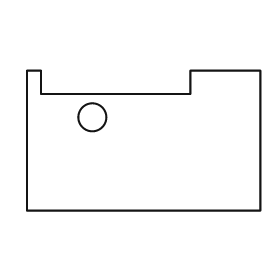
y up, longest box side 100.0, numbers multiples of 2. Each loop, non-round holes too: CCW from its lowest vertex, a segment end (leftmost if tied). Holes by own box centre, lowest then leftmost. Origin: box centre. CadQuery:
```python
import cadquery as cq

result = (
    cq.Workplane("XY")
    .moveTo(-50.0, -30.0)
    .lineTo(50.0, -30.0)
    .lineTo(50.0, 30.0)
    .lineTo(20.0, 30.0)
    .lineTo(20.0, 20.0)
    .lineTo(-44.0, 20.0)
    .lineTo(-44.0, 30.0)
    .lineTo(-50.0, 30.0)
    .close()
    .moveTo(-22.0, 10.0)
    .circle(6.0)
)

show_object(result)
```